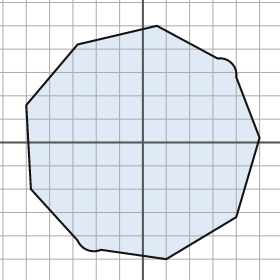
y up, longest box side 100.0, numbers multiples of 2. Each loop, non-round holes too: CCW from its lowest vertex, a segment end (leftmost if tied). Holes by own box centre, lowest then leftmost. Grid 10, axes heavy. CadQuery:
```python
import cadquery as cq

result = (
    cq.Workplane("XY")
    .moveTo(10.0, -50.0)
    .lineTo(40.0, -32.0)
    .lineTo(50.0, 2.0)
    .lineTo(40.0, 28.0)
    .threePointArc((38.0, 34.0), (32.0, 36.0))
    .lineTo(6.0, 50.0)
    .lineTo(-28.0, 42.0)
    .lineTo(-50.0, 16.0)
    .lineTo(-48.0, -20.0)
    .lineTo(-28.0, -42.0)
    .threePointArc((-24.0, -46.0), (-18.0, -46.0))
    .close()
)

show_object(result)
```